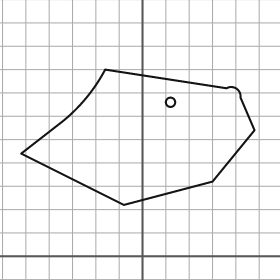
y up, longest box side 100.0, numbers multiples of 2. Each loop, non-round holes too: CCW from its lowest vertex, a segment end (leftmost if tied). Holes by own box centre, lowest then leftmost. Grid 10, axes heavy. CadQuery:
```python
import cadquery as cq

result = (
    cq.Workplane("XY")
    .moveTo(-8.0, 22.0)
    .lineTo(30.0, 32.0)
    .lineTo(48.0, 54.0)
    .lineTo(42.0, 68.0)
    .threePointArc((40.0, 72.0), (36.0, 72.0))
    .lineTo(-16.0, 80.0)
    .threePointArc((-24.0, 68.0), (-34.0, 58.0))
    .lineTo(-52.0, 44.0)
    .close()
    .moveTo(12.0, 66.0)
    .circle(2.0)
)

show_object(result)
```